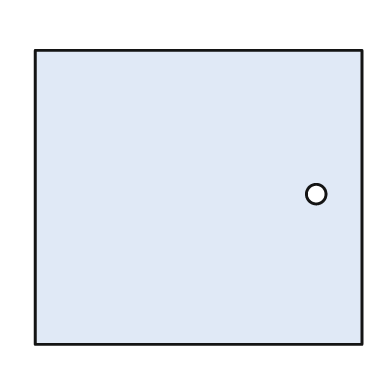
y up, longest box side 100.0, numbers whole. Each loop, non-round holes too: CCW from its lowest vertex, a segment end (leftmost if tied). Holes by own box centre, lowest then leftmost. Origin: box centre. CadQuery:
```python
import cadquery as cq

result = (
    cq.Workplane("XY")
    .moveTo(-50.0, -45.0)
    .lineTo(50.0, -45.0)
    .lineTo(50.0, 45.0)
    .lineTo(-50.0, 45.0)
    .close()
    .moveTo(36.0, 1.0)
    .circle(3.0)
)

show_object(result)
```